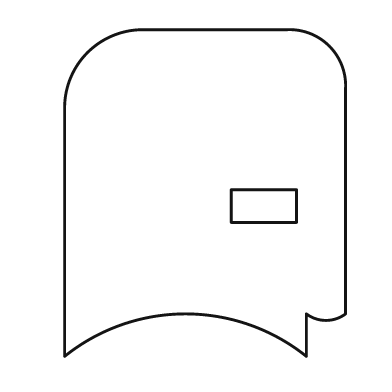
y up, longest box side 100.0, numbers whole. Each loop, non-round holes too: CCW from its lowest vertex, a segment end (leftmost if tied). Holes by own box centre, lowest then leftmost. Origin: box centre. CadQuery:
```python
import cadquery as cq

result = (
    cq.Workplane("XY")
    .moveTo(-43.0, -50.0)
    .threePointArc((-6.0, -37.0), (31.0, -50.0))
    .lineTo(31.0, -37.0)
    .threePointArc((37.0, -39.0), (43.0, -37.0))
    .lineTo(43.0, 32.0)
    .threePointArc((38.0, 45.0), (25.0, 50.0))
    .lineTo(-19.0, 50.0)
    .threePointArc((-36.0, 43.0), (-43.0, 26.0))
    .close()
    .moveTo(8.0, -9.0)
    .lineTo(28.0, -9.0)
    .lineTo(28.0, 1.0)
    .lineTo(8.0, 1.0)
    .close()
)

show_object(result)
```